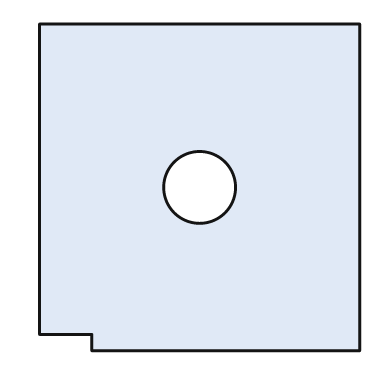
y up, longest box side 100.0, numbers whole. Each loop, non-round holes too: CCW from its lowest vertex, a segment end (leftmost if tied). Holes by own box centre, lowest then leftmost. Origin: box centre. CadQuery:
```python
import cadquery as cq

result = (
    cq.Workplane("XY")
    .moveTo(-33.0, -50.0)
    .lineTo(49.0, -50.0)
    .lineTo(49.0, 50.0)
    .lineTo(-49.0, 50.0)
    .lineTo(-49.0, -45.0)
    .lineTo(-33.0, -45.0)
    .close()
    .moveTo(0.0, 0.0)
    .circle(11.0)
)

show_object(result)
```